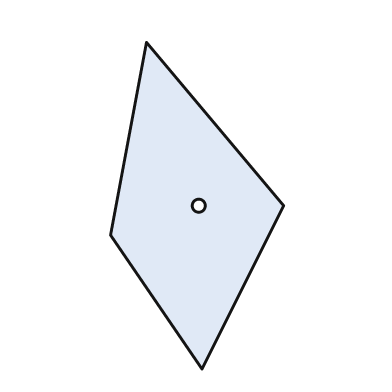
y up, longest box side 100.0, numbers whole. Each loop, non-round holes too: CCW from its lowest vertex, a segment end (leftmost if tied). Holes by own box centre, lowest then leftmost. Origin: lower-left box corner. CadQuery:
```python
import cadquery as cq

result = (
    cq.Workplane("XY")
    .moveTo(28.0, 0.0)
    .lineTo(53.0, 50.0)
    .lineTo(11.0, 100.0)
    .lineTo(0.0, 41.0)
    .close()
    .moveTo(27.0, 50.0)
    .circle(2.0)
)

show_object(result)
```